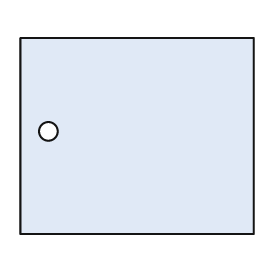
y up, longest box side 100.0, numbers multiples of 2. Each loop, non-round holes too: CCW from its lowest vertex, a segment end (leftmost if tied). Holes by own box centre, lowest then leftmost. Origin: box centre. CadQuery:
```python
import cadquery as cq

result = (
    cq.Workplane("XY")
    .moveTo(-50.0, -42.0)
    .lineTo(50.0, -42.0)
    .lineTo(50.0, 42.0)
    .lineTo(-50.0, 42.0)
    .close()
    .moveTo(-38.0, 2.0)
    .circle(4.0)
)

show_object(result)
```